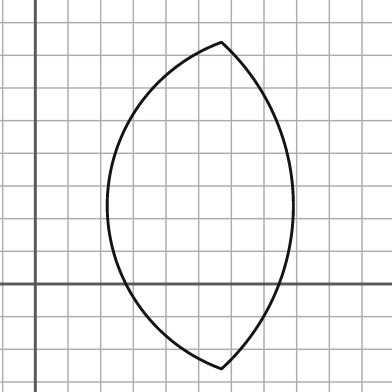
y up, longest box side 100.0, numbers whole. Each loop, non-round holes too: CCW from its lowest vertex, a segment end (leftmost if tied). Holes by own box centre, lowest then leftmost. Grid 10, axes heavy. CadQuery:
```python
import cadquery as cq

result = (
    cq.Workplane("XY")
    .moveTo(57.0, -26.0)
    .threePointArc((79.0, 24.0), (57.0, 74.0))
    .threePointArc((22.0, 24.0), (57.0, -26.0))
    .close()
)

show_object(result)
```